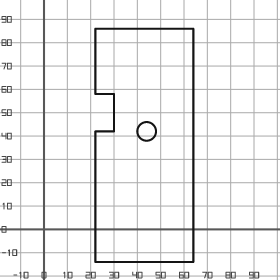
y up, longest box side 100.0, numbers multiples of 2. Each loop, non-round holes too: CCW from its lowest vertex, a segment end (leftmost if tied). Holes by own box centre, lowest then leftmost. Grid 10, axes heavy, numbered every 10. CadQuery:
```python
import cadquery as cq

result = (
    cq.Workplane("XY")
    .moveTo(22.0, -14.0)
    .lineTo(64.0, -14.0)
    .lineTo(64.0, 86.0)
    .lineTo(22.0, 86.0)
    .lineTo(22.0, 58.0)
    .lineTo(30.0, 58.0)
    .lineTo(30.0, 42.0)
    .lineTo(22.0, 42.0)
    .close()
    .moveTo(44.0, 42.0)
    .circle(4.0)
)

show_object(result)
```